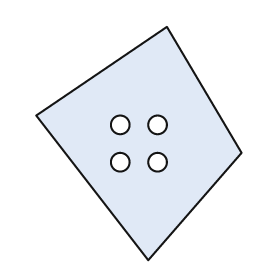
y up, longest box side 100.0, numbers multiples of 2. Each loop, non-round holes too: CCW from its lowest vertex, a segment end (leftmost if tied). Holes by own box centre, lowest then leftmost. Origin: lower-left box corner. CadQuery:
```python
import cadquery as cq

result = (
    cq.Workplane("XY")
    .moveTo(48.0, 0.0)
    .lineTo(88.0, 46.0)
    .lineTo(56.0, 100.0)
    .lineTo(0.0, 62.0)
    .close()
    .moveTo(36.0, 42.0)
    .circle(4.0)
    .moveTo(52.0, 42.0)
    .circle(4.0)
    .moveTo(36.0, 58.0)
    .circle(4.0)
    .moveTo(52.0, 58.0)
    .circle(4.0)
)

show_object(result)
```